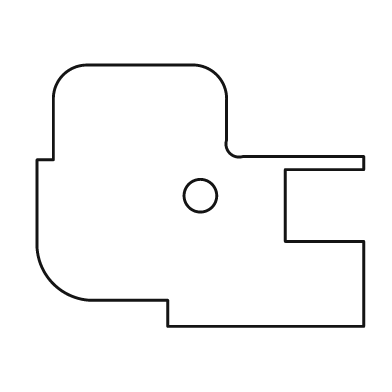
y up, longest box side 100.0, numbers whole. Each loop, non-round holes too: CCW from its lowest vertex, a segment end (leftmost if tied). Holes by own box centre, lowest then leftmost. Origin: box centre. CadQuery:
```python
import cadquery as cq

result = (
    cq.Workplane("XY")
    .moveTo(-10.0, -40.0)
    .lineTo(50.0, -40.0)
    .lineTo(50.0, -14.0)
    .lineTo(26.0, -14.0)
    .lineTo(26.0, 8.0)
    .lineTo(50.0, 8.0)
    .lineTo(50.0, 12.0)
    .lineTo(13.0, 12.0)
    .threePointArc((9.0, 13.0), (8.0, 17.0))
    .lineTo(8.0, 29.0)
    .threePointArc((5.0, 37.0), (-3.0, 40.0))
    .lineTo(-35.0, 40.0)
    .threePointArc((-42.0, 37.0), (-45.0, 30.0))
    .lineTo(-45.0, 11.0)
    .lineTo(-50.0, 11.0)
    .lineTo(-50.0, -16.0)
    .threePointArc((-45.0, -27.0), (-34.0, -32.0))
    .lineTo(-10.0, -32.0)
    .close()
    .moveTo(0.0, 0.0)
    .circle(5.0)
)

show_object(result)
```